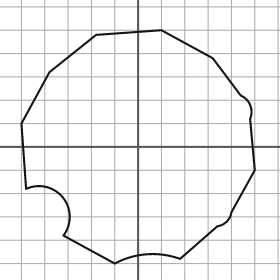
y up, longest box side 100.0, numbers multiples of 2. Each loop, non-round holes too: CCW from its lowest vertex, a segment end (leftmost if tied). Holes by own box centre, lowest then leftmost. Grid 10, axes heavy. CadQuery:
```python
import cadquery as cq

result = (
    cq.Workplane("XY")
    .moveTo(-10.0, -50.0)
    .threePointArc((4.0, -46.0), (18.0, -48.0))
    .lineTo(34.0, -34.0)
    .threePointArc((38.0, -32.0), (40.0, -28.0))
    .lineTo(50.0, -10.0)
    .lineTo(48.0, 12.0)
    .threePointArc((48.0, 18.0), (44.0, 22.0))
    .lineTo(32.0, 38.0)
    .lineTo(10.0, 50.0)
    .lineTo(-18.0, 48.0)
    .lineTo(-38.0, 32.0)
    .lineTo(-50.0, 10.0)
    .lineTo(-48.0, -18.0)
    .threePointArc((-32.0, -22.0), (-32.0, -38.0))
    .close()
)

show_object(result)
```